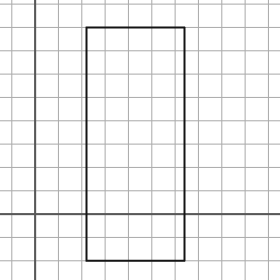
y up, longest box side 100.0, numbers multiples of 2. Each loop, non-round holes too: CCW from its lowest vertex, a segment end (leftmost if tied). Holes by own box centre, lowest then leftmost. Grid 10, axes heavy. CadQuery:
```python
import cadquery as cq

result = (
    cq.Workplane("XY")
    .moveTo(22.0, -20.0)
    .lineTo(64.0, -20.0)
    .lineTo(64.0, 80.0)
    .lineTo(22.0, 80.0)
    .close()
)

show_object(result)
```